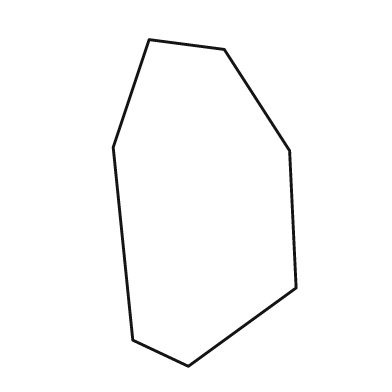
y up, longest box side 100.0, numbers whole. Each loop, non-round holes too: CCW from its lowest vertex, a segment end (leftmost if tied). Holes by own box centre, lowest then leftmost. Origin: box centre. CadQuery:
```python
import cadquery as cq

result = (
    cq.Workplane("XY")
    .moveTo(-5.0, -50.0)
    .lineTo(28.0, -26.0)
    .lineTo(26.0, 16.0)
    .lineTo(6.0, 47.0)
    .lineTo(-17.0, 50.0)
    .lineTo(-28.0, 17.0)
    .lineTo(-22.0, -42.0)
    .close()
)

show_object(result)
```